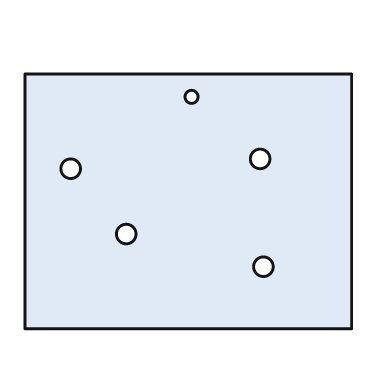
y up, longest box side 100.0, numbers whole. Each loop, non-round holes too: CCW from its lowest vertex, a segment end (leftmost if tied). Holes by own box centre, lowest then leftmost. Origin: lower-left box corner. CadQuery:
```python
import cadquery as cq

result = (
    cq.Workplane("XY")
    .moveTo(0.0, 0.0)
    .lineTo(100.0, 0.0)
    .lineTo(100.0, 78.0)
    .lineTo(0.0, 78.0)
    .close()
    .moveTo(73.0, 19.0)
    .circle(3.0)
    .moveTo(31.0, 29.0)
    .circle(3.0)
    .moveTo(14.0, 49.0)
    .circle(3.0)
    .moveTo(72.0, 52.0)
    .circle(3.0)
    .moveTo(51.0, 71.0)
    .circle(2.0)
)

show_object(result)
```